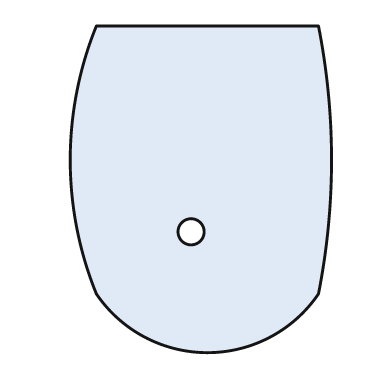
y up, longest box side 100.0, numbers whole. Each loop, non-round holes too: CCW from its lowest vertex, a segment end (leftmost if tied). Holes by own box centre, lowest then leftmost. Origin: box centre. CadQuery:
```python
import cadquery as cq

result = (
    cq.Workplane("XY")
    .moveTo(-32.0, -32.0)
    .threePointArc((2.0, -50.0), (36.0, -32.0))
    .threePointArc((40.0, 9.0), (36.0, 50.0))
    .lineTo(-32.0, 50.0)
    .threePointArc((-40.0, 9.0), (-32.0, -32.0))
    .close()
    .moveTo(-3.0, -13.0)
    .circle(4.0)
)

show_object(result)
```